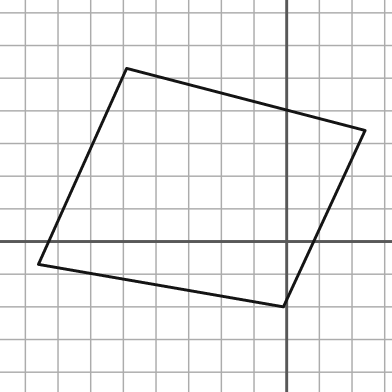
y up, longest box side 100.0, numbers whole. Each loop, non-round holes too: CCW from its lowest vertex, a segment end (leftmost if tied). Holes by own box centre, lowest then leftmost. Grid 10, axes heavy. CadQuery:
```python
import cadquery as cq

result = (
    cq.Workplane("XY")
    .moveTo(-1.0, -20.0)
    .lineTo(24.0, 34.0)
    .lineTo(-49.0, 53.0)
    .lineTo(-76.0, -7.0)
    .close()
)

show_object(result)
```